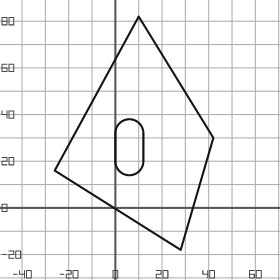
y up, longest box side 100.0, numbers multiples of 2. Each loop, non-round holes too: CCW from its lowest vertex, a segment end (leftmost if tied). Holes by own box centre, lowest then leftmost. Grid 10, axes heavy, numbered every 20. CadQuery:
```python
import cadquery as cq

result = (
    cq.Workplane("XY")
    .moveTo(28.0, -18.0)
    .lineTo(42.0, 30.0)
    .lineTo(10.0, 82.0)
    .lineTo(-26.0, 16.0)
    .close()
    .moveTo(0.0, 20.0)
    .threePointArc((6.0, 14.0), (12.0, 20.0))
    .lineTo(12.0, 32.0)
    .threePointArc((6.0, 38.0), (0.0, 32.0))
    .close()
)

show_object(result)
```